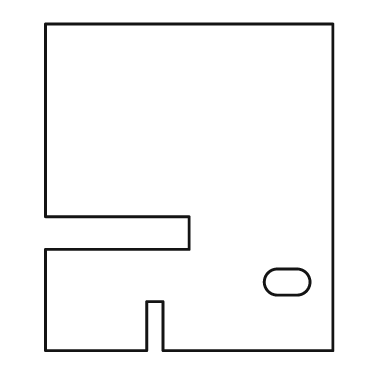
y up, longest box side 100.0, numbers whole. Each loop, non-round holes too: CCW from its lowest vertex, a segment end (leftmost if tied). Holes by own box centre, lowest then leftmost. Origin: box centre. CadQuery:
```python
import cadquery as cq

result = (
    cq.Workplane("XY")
    .moveTo(-44.0, -50.0)
    .lineTo(-13.0, -50.0)
    .lineTo(-13.0, -35.0)
    .lineTo(-8.0, -35.0)
    .lineTo(-8.0, -50.0)
    .lineTo(44.0, -50.0)
    .lineTo(44.0, 50.0)
    .lineTo(-44.0, 50.0)
    .lineTo(-44.0, -9.0)
    .lineTo(0.0, -9.0)
    .lineTo(0.0, -19.0)
    .lineTo(-44.0, -19.0)
    .close()
    .moveTo(27.0, -33.0)
    .lineTo(33.0, -33.0)
    .threePointArc((37.0, -29.0), (33.0, -25.0))
    .lineTo(27.0, -25.0)
    .threePointArc((23.0, -29.0), (27.0, -33.0))
    .close()
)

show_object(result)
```